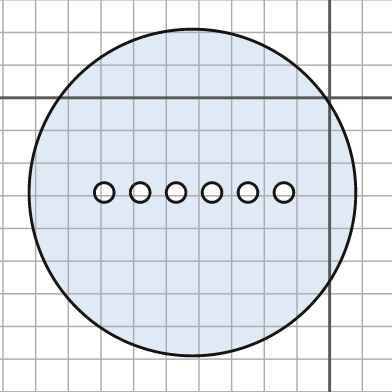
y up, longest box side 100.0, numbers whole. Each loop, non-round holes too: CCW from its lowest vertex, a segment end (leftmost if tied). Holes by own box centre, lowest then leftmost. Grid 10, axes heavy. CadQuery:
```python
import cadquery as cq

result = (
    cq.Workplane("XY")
    .moveTo(-42.0, -29.0)
    .circle(50.0)
    .moveTo(-69.0, -29.0)
    .circle(3.0)
    .moveTo(-58.0, -29.0)
    .circle(3.0)
    .moveTo(-47.0, -29.0)
    .circle(3.0)
    .moveTo(-36.0, -29.0)
    .circle(3.0)
    .moveTo(-25.0, -29.0)
    .circle(3.0)
    .moveTo(-14.0, -29.0)
    .circle(3.0)
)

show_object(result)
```